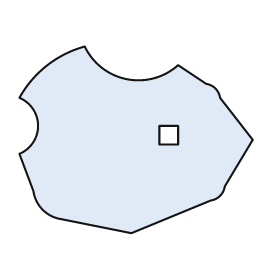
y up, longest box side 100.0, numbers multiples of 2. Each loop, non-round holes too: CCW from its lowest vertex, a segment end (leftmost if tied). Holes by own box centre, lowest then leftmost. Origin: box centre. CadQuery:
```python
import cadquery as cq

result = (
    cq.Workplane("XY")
    .moveTo(-2.0, -40.0)
    .lineTo(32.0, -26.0)
    .threePointArc((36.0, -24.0), (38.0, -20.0))
    .lineTo(50.0, 0.0)
    .lineTo(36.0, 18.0)
    .threePointArc((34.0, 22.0), (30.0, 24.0))
    .lineTo(18.0, 32.0)
    .threePointArc((-4.0, 26.0), (-22.0, 40.0))
    .threePointArc((-38.0, 32.0), (-50.0, 18.0))
    .threePointArc((-42.0, 6.0), (-50.0, -6.0))
    .lineTo(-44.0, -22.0)
    .threePointArc((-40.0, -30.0), (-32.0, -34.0))
    .close()
    .moveTo(10.0, -2.0)
    .lineTo(18.0, -2.0)
    .lineTo(18.0, 6.0)
    .lineTo(10.0, 6.0)
    .close()
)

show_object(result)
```